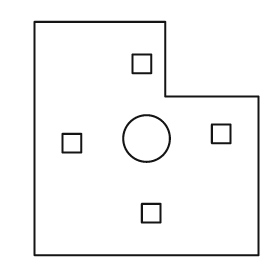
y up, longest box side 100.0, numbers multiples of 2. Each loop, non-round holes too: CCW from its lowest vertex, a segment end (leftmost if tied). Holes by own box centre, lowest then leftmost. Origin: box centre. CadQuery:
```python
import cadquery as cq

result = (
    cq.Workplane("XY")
    .moveTo(-48.0, -50.0)
    .lineTo(48.0, -50.0)
    .lineTo(48.0, 18.0)
    .lineTo(8.0, 18.0)
    .lineTo(8.0, 50.0)
    .lineTo(-48.0, 50.0)
    .close()
    .moveTo(-2.0, -36.0)
    .lineTo(6.0, -36.0)
    .lineTo(6.0, -28.0)
    .lineTo(-2.0, -28.0)
    .close()
    .moveTo(-36.0, -6.0)
    .lineTo(-28.0, -6.0)
    .lineTo(-28.0, 2.0)
    .lineTo(-36.0, 2.0)
    .close()
    .moveTo(0.0, 0.0)
    .circle(10.0)
    .moveTo(28.0, -2.0)
    .lineTo(36.0, -2.0)
    .lineTo(36.0, 6.0)
    .lineTo(28.0, 6.0)
    .close()
    .moveTo(-6.0, 28.0)
    .lineTo(2.0, 28.0)
    .lineTo(2.0, 36.0)
    .lineTo(-6.0, 36.0)
    .close()
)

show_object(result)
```